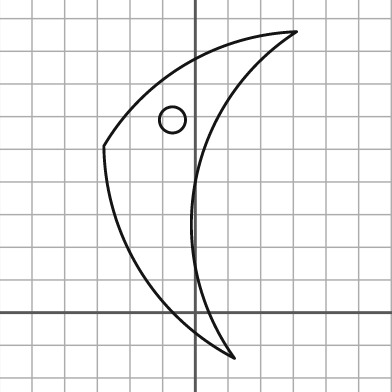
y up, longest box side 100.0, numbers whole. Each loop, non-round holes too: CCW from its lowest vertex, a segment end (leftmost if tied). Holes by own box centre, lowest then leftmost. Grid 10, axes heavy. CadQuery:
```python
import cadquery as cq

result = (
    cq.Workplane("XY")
    .moveTo(12.0, -14.0)
    .threePointArc((0.0, 40.0), (31.0, 86.0))
    .threePointArc((-3.0, 76.0), (-28.0, 51.0))
    .threePointArc((-17.0, 13.0), (12.0, -14.0))
    .close()
    .moveTo(-7.0, 59.0)
    .circle(4.0)
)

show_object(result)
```